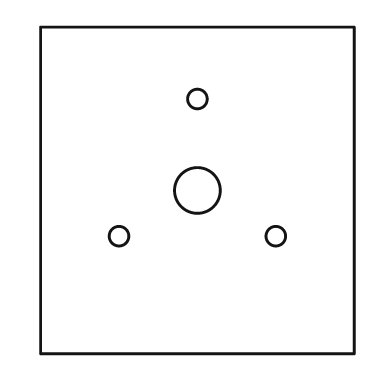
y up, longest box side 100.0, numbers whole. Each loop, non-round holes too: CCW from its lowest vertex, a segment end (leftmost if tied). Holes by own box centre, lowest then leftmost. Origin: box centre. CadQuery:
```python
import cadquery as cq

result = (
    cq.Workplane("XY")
    .moveTo(-48.0, -50.0)
    .lineTo(48.0, -50.0)
    .lineTo(48.0, 50.0)
    .lineTo(-48.0, 50.0)
    .close()
    .moveTo(-24.0, -14.0)
    .circle(3.0)
    .moveTo(24.0, -14.0)
    .circle(3.0)
    .moveTo(0.0, 0.0)
    .circle(7.0)
    .moveTo(0.0, 28.0)
    .circle(3.0)
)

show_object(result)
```